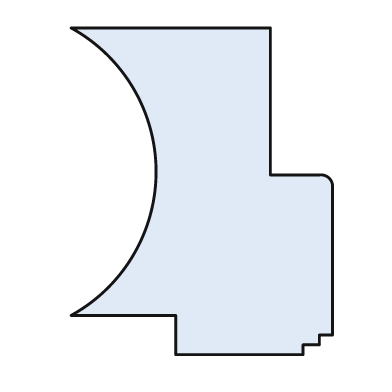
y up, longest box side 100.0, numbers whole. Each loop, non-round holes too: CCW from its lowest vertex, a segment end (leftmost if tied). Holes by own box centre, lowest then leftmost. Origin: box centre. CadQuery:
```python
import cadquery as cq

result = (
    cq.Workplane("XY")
    .moveTo(-8.0, -50.0)
    .lineTo(31.0, -50.0)
    .lineTo(31.0, -47.0)
    .lineTo(36.0, -47.0)
    .lineTo(36.0, -44.0)
    .lineTo(40.0, -44.0)
    .lineTo(40.0, 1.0)
    .threePointArc((39.0, 4.0), (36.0, 5.0))
    .lineTo(21.0, 5.0)
    .lineTo(21.0, 50.0)
    .lineTo(-40.0, 50.0)
    .threePointArc((-14.0, 6.0), (-40.0, -38.0))
    .lineTo(-8.0, -38.0)
    .close()
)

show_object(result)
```